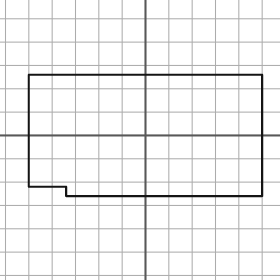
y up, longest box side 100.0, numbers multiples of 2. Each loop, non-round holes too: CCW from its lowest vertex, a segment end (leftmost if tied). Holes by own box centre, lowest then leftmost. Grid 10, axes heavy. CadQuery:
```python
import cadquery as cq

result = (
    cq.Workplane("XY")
    .moveTo(-34.0, -26.0)
    .lineTo(50.0, -26.0)
    .lineTo(50.0, 26.0)
    .lineTo(-50.0, 26.0)
    .lineTo(-50.0, -22.0)
    .lineTo(-34.0, -22.0)
    .close()
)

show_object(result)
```